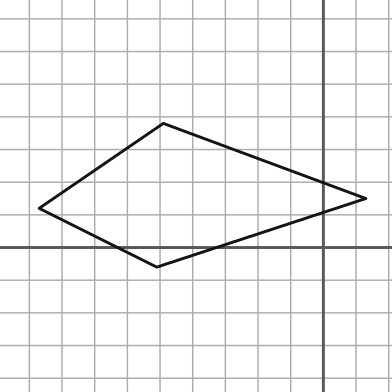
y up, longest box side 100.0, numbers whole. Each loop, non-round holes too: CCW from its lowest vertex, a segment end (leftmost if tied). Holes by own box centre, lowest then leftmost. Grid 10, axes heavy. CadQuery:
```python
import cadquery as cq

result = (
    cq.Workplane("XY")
    .moveTo(-51.0, -6.0)
    .lineTo(13.0, 15.0)
    .lineTo(-49.0, 38.0)
    .lineTo(-87.0, 12.0)
    .close()
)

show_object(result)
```